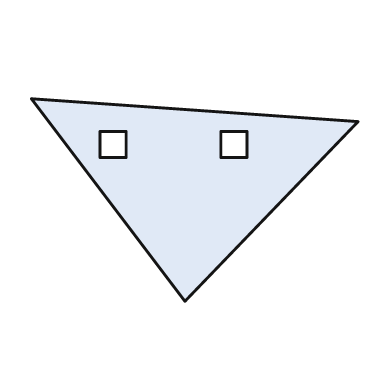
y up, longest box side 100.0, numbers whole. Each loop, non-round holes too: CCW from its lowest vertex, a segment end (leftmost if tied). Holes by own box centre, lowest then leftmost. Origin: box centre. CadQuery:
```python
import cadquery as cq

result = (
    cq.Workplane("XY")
    .moveTo(-3.0, -31.0)
    .lineTo(50.0, 24.0)
    .lineTo(-50.0, 31.0)
    .close()
    .moveTo(-29.0, 13.0)
    .lineTo(-21.0, 13.0)
    .lineTo(-21.0, 21.0)
    .lineTo(-29.0, 21.0)
    .close()
    .moveTo(8.0, 13.0)
    .lineTo(16.0, 13.0)
    .lineTo(16.0, 21.0)
    .lineTo(8.0, 21.0)
    .close()
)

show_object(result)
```